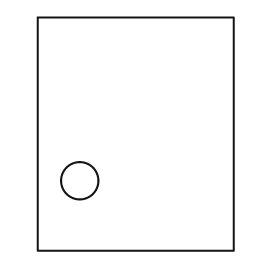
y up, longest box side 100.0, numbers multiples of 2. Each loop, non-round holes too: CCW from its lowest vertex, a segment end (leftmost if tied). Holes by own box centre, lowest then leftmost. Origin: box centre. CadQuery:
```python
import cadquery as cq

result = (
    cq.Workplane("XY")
    .moveTo(-42.0, -50.0)
    .lineTo(42.0, -50.0)
    .lineTo(42.0, 50.0)
    .lineTo(-42.0, 50.0)
    .close()
    .moveTo(-24.0, -20.0)
    .circle(8.0)
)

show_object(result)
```